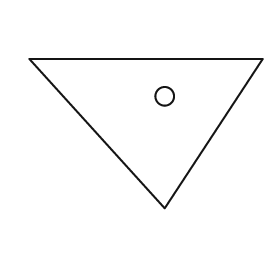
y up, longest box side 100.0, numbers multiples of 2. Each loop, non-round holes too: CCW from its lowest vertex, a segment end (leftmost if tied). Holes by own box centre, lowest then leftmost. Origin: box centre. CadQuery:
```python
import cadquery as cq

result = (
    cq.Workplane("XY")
    .moveTo(8.0, -32.0)
    .lineTo(50.0, 32.0)
    .lineTo(-50.0, 32.0)
    .close()
    .moveTo(8.0, 16.0)
    .circle(4.0)
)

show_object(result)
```